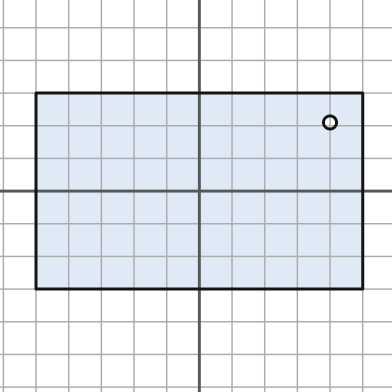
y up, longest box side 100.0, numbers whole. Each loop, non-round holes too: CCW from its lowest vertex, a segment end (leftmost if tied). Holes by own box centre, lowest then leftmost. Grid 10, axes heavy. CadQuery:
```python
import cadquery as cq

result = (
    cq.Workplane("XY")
    .moveTo(-50.0, -30.0)
    .lineTo(50.0, -30.0)
    .lineTo(50.0, 30.0)
    .lineTo(-50.0, 30.0)
    .close()
    .moveTo(40.0, 21.0)
    .circle(2.0)
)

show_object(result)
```